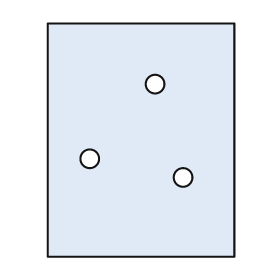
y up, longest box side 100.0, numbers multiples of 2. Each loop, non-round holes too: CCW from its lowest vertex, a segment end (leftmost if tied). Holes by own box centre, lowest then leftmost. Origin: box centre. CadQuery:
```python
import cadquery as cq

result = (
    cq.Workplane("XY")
    .moveTo(-40.0, -50.0)
    .lineTo(40.0, -50.0)
    .lineTo(40.0, 50.0)
    .lineTo(-40.0, 50.0)
    .close()
    .moveTo(18.0, -16.0)
    .circle(4.0)
    .moveTo(-22.0, -8.0)
    .circle(4.0)
    .moveTo(6.0, 24.0)
    .circle(4.0)
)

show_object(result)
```